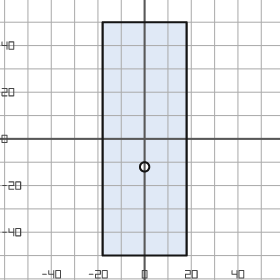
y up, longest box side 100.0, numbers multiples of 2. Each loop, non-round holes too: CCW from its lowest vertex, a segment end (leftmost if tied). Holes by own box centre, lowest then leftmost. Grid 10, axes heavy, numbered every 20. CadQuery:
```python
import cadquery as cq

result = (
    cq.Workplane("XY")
    .moveTo(-18.0, -50.0)
    .lineTo(18.0, -50.0)
    .lineTo(18.0, 50.0)
    .lineTo(-18.0, 50.0)
    .close()
    .moveTo(0.0, -12.0)
    .circle(2.0)
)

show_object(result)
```